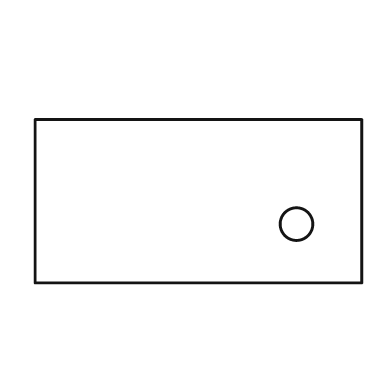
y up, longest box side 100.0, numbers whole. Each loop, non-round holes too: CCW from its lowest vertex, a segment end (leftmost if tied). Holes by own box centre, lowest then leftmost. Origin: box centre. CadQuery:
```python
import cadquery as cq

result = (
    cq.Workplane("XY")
    .moveTo(-50.0, -25.0)
    .lineTo(50.0, -25.0)
    .lineTo(50.0, 25.0)
    .lineTo(-50.0, 25.0)
    .close()
    .moveTo(30.0, -7.0)
    .circle(5.0)
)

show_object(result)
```